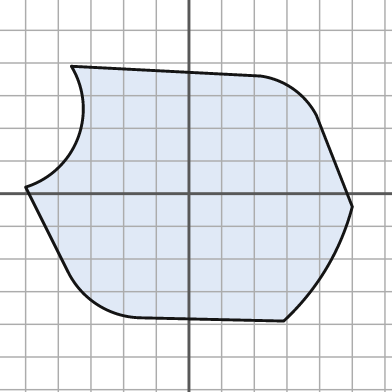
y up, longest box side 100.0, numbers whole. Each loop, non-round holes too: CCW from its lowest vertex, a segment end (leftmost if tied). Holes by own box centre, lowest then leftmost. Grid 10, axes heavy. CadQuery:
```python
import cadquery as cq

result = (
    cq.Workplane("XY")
    .moveTo(29.0, -39.0)
    .threePointArc((42.0, -23.0), (50.0, -4.0))
    .lineTo(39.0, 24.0)
    .threePointArc((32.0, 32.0), (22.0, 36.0))
    .lineTo(-36.0, 39.0)
    .threePointArc((-34.0, 17.0), (-50.0, 2.0))
    .lineTo(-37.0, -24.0)
    .threePointArc((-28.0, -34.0), (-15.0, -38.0))
    .close()
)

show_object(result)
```